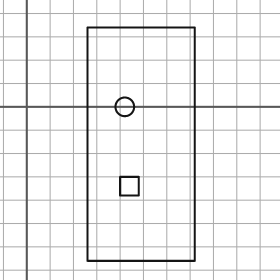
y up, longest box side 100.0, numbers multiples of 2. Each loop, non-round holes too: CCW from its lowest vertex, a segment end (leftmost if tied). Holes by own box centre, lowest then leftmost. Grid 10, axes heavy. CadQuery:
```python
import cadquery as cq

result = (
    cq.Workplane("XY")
    .moveTo(26.0, -66.0)
    .lineTo(72.0, -66.0)
    .lineTo(72.0, 34.0)
    .lineTo(26.0, 34.0)
    .close()
    .moveTo(40.0, -38.0)
    .lineTo(48.0, -38.0)
    .lineTo(48.0, -30.0)
    .lineTo(40.0, -30.0)
    .close()
    .moveTo(42.0, 0.0)
    .circle(4.0)
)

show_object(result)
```